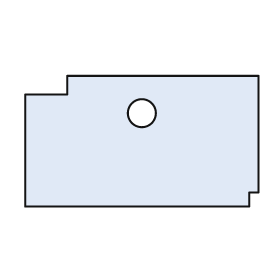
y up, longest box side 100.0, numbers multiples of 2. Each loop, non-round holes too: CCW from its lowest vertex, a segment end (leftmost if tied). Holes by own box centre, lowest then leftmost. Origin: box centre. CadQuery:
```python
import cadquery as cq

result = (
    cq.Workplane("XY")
    .moveTo(-50.0, -28.0)
    .lineTo(46.0, -28.0)
    .lineTo(46.0, -22.0)
    .lineTo(50.0, -22.0)
    .lineTo(50.0, 28.0)
    .lineTo(-32.0, 28.0)
    .lineTo(-32.0, 20.0)
    .lineTo(-50.0, 20.0)
    .close()
    .moveTo(0.0, 12.0)
    .circle(6.0)
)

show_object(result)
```